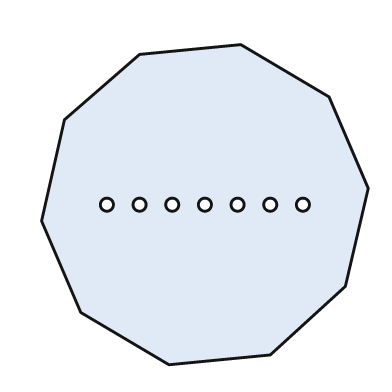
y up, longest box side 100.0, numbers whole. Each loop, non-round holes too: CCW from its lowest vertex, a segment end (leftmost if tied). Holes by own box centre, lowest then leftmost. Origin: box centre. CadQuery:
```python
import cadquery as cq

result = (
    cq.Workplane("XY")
    .moveTo(-11.0, -49.0)
    .lineTo(20.0, -46.0)
    .lineTo(43.0, -25.0)
    .lineTo(50.0, 5.0)
    .lineTo(38.0, 33.0)
    .lineTo(11.0, 49.0)
    .lineTo(-20.0, 46.0)
    .lineTo(-43.0, 26.0)
    .lineTo(-50.0, -5.0)
    .lineTo(-38.0, -33.0)
    .close()
    .moveTo(-30.0, 0.0)
    .circle(2.0)
    .moveTo(-20.0, 0.0)
    .circle(2.0)
    .moveTo(-10.0, 0.0)
    .circle(2.0)
    .moveTo(0.0, 0.0)
    .circle(2.0)
    .moveTo(10.0, 0.0)
    .circle(2.0)
    .moveTo(20.0, 0.0)
    .circle(2.0)
    .moveTo(30.0, 0.0)
    .circle(2.0)
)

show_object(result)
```